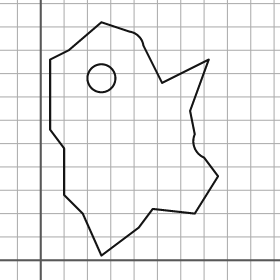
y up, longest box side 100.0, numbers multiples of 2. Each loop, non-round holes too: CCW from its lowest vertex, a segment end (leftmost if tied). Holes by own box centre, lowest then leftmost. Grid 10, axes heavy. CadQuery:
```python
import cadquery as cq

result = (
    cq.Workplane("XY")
    .moveTo(26.0, 2.0)
    .lineTo(42.0, 14.0)
    .lineTo(48.0, 22.0)
    .lineTo(66.0, 20.0)
    .lineTo(76.0, 36.0)
    .lineTo(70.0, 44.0)
    .threePointArc((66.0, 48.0), (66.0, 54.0))
    .lineTo(64.0, 64.0)
    .lineTo(72.0, 86.0)
    .lineTo(52.0, 76.0)
    .lineTo(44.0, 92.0)
    .threePointArc((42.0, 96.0), (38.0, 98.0))
    .lineTo(26.0, 102.0)
    .lineTo(12.0, 90.0)
    .lineTo(4.0, 86.0)
    .lineTo(4.0, 56.0)
    .lineTo(10.0, 48.0)
    .lineTo(10.0, 28.0)
    .lineTo(18.0, 20.0)
    .close()
    .moveTo(26.0, 78.0)
    .circle(6.0)
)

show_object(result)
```